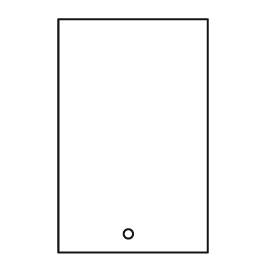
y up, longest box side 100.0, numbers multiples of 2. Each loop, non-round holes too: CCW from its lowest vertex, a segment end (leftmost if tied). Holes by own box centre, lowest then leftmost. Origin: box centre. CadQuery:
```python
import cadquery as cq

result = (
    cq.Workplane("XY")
    .moveTo(-32.0, -50.0)
    .lineTo(32.0, -50.0)
    .lineTo(32.0, 50.0)
    .lineTo(-32.0, 50.0)
    .close()
    .moveTo(-2.0, -42.0)
    .circle(2.0)
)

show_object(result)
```